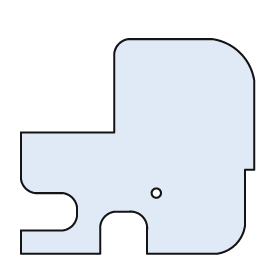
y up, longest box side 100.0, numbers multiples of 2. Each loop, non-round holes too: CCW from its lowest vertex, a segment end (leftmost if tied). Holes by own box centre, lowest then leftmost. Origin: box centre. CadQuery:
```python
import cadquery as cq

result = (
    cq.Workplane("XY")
    .moveTo(-50.0, -46.0)
    .lineTo(-16.0, -46.0)
    .lineTo(-16.0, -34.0)
    .threePointArc((-14.0, -30.0), (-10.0, -28.0))
    .lineTo(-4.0, -28.0)
    .threePointArc((2.0, -30.0), (4.0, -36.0))
    .lineTo(4.0, -46.0)
    .lineTo(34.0, -46.0)
    .threePointArc((42.0, -42.0), (46.0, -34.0))
    .lineTo(46.0, -10.0)
    .lineTo(50.0, -10.0)
    .lineTo(50.0, 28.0)
    .threePointArc((44.0, 40.0), (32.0, 46.0))
    .lineTo(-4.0, 46.0)
    .threePointArc((-8.0, 44.0), (-10.0, 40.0))
    .lineTo(-10.0, 6.0)
    .lineTo(-50.0, 6.0)
    .lineTo(-50.0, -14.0)
    .threePointArc((-48.0, -18.0), (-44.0, -20.0))
    .lineTo(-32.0, -20.0)
    .threePointArc((-28.0, -22.0), (-26.0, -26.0))
    .lineTo(-26.0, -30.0)
    .threePointArc((-28.0, -34.0), (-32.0, -36.0))
    .lineTo(-50.0, -36.0)
    .close()
    .moveTo(8.0, -20.0)
    .circle(2.0)
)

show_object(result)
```